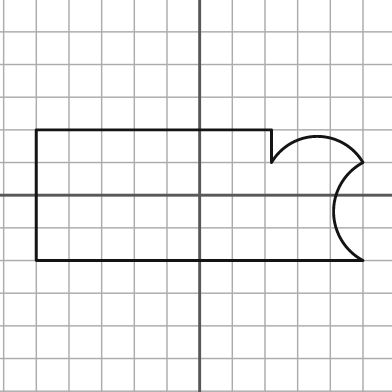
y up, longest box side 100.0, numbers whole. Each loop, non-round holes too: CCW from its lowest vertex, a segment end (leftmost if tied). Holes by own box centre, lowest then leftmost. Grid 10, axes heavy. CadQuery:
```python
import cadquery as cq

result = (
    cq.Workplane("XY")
    .moveTo(-50.0, -20.0)
    .lineTo(50.0, -20.0)
    .threePointArc((41.0, -5.0), (50.0, 10.0))
    .threePointArc((36.0, 18.0), (22.0, 10.0))
    .lineTo(22.0, 20.0)
    .lineTo(-50.0, 20.0)
    .close()
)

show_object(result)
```